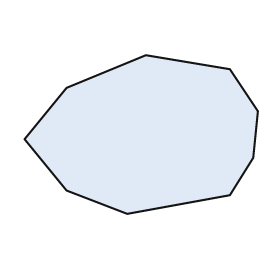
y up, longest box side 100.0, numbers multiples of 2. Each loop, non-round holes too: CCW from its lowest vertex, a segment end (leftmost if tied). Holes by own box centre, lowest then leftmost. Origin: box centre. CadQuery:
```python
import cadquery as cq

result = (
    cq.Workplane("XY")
    .moveTo(-6.0, -34.0)
    .lineTo(38.0, -26.0)
    .lineTo(48.0, -10.0)
    .lineTo(50.0, 10.0)
    .lineTo(38.0, 28.0)
    .lineTo(2.0, 34.0)
    .lineTo(-32.0, 20.0)
    .lineTo(-50.0, -2.0)
    .lineTo(-32.0, -24.0)
    .close()
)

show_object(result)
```